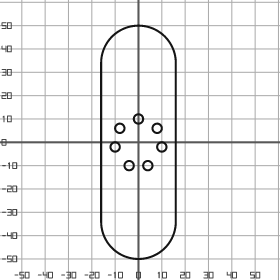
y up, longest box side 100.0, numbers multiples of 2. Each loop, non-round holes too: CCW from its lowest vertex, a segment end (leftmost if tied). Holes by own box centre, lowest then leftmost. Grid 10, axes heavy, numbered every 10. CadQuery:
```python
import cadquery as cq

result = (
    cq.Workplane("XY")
    .moveTo(-16.0, -34.0)
    .threePointArc((0.0, -50.0), (16.0, -34.0))
    .lineTo(16.0, 34.0)
    .threePointArc((0.0, 50.0), (-16.0, 34.0))
    .close()
    .moveTo(-4.0, -10.0)
    .circle(2.0)
    .moveTo(4.0, -10.0)
    .circle(2.0)
    .moveTo(-10.0, -2.0)
    .circle(2.0)
    .moveTo(10.0, -2.0)
    .circle(2.0)
    .moveTo(-8.0, 6.0)
    .circle(2.0)
    .moveTo(8.0, 6.0)
    .circle(2.0)
    .moveTo(0.0, 10.0)
    .circle(2.0)
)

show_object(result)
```